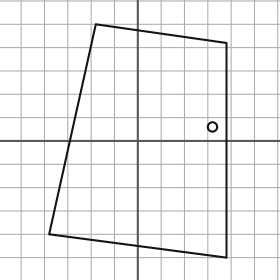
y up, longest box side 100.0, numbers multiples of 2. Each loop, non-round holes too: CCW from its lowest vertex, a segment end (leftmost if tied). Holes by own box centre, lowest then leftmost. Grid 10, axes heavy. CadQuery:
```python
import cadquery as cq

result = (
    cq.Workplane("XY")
    .moveTo(38.0, -50.0)
    .lineTo(38.0, 42.0)
    .lineTo(-18.0, 50.0)
    .lineTo(-38.0, -40.0)
    .close()
    .moveTo(32.0, 6.0)
    .circle(2.0)
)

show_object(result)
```